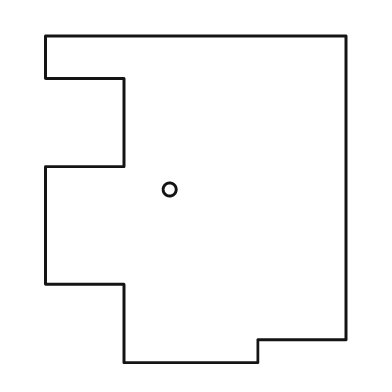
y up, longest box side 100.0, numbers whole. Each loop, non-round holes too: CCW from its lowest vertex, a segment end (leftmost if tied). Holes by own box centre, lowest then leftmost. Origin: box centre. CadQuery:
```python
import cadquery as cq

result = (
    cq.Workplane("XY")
    .moveTo(-22.0, -50.0)
    .lineTo(19.0, -50.0)
    .lineTo(19.0, -43.0)
    .lineTo(46.0, -43.0)
    .lineTo(46.0, 50.0)
    .lineTo(-46.0, 50.0)
    .lineTo(-46.0, 37.0)
    .lineTo(-22.0, 37.0)
    .lineTo(-22.0, 10.0)
    .lineTo(-46.0, 10.0)
    .lineTo(-46.0, -26.0)
    .lineTo(-22.0, -26.0)
    .close()
    .moveTo(-8.0, 3.0)
    .circle(2.0)
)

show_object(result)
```